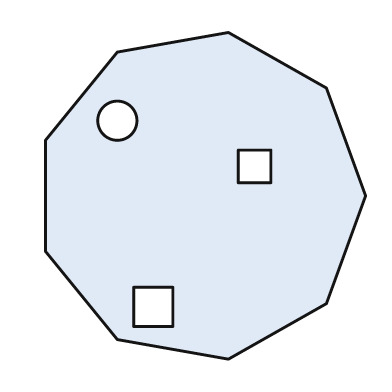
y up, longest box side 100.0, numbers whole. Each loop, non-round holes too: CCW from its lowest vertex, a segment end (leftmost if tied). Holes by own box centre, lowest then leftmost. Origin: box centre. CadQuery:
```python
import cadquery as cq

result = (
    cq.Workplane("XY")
    .moveTo(7.0, -50.0)
    .lineTo(37.0, -33.0)
    .lineTo(49.0, 0.0)
    .lineTo(37.0, 33.0)
    .lineTo(7.0, 50.0)
    .lineTo(-27.0, 44.0)
    .lineTo(-49.0, 17.0)
    .lineTo(-49.0, -17.0)
    .lineTo(-27.0, -44.0)
    .close()
    .moveTo(-22.0, -40.0)
    .lineTo(-10.0, -40.0)
    .lineTo(-10.0, -28.0)
    .lineTo(-22.0, -28.0)
    .close()
    .moveTo(10.0, 4.0)
    .lineTo(20.0, 4.0)
    .lineTo(20.0, 14.0)
    .lineTo(10.0, 14.0)
    .close()
    .moveTo(-27.0, 23.0)
    .circle(6.0)
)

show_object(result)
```